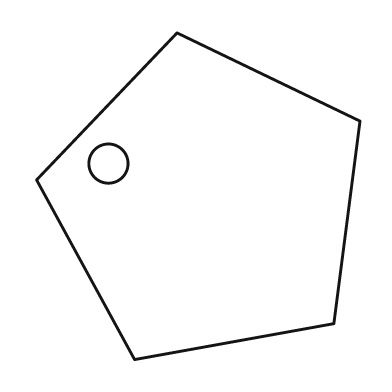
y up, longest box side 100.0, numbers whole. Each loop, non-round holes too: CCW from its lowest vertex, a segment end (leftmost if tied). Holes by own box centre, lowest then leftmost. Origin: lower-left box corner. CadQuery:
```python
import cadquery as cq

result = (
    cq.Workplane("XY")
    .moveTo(30.0, 0.0)
    .lineTo(91.0, 11.0)
    .lineTo(99.0, 73.0)
    .lineTo(43.0, 100.0)
    .lineTo(0.0, 55.0)
    .close()
    .moveTo(22.0, 60.0)
    .circle(6.0)
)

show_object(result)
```